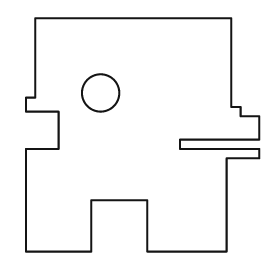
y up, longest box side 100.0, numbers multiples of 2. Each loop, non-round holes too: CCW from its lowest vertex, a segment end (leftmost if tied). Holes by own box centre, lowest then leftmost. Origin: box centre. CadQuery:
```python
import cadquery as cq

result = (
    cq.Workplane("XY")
    .moveTo(-50.0, -50.0)
    .lineTo(-22.0, -50.0)
    .lineTo(-22.0, -28.0)
    .lineTo(2.0, -28.0)
    .lineTo(2.0, -50.0)
    .lineTo(36.0, -50.0)
    .lineTo(36.0, -10.0)
    .lineTo(50.0, -10.0)
    .lineTo(50.0, -6.0)
    .lineTo(16.0, -6.0)
    .lineTo(16.0, -2.0)
    .lineTo(50.0, -2.0)
    .lineTo(50.0, 8.0)
    .lineTo(42.0, 8.0)
    .lineTo(42.0, 12.0)
    .lineTo(38.0, 12.0)
    .lineTo(38.0, 50.0)
    .lineTo(-46.0, 50.0)
    .lineTo(-46.0, 16.0)
    .lineTo(-50.0, 16.0)
    .lineTo(-50.0, 10.0)
    .lineTo(-36.0, 10.0)
    .lineTo(-36.0, -6.0)
    .lineTo(-50.0, -6.0)
    .close()
    .moveTo(-18.0, 18.0)
    .circle(8.0)
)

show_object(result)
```